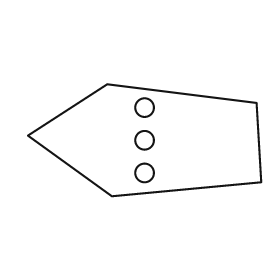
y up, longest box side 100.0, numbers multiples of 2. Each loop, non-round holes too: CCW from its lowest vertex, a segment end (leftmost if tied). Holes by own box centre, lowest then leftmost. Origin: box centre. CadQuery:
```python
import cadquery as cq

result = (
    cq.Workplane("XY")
    .moveTo(-14.0, -24.0)
    .lineTo(50.0, -18.0)
    .lineTo(48.0, 16.0)
    .lineTo(-16.0, 24.0)
    .lineTo(-50.0, 2.0)
    .close()
    .moveTo(0.0, -14.0)
    .circle(4.0)
    .moveTo(0.0, 0.0)
    .circle(4.0)
    .moveTo(0.0, 14.0)
    .circle(4.0)
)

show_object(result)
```